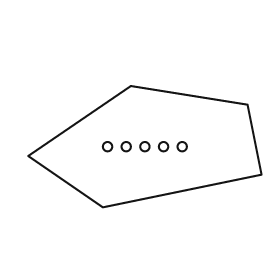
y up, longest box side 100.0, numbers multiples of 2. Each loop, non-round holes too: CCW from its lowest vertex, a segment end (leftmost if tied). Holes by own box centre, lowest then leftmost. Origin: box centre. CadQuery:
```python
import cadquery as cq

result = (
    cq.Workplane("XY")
    .moveTo(-18.0, -26.0)
    .lineTo(50.0, -12.0)
    .lineTo(44.0, 18.0)
    .lineTo(-6.0, 26.0)
    .lineTo(-50.0, -4.0)
    .close()
    .moveTo(-16.0, 0.0)
    .circle(2.0)
    .moveTo(-8.0, 0.0)
    .circle(2.0)
    .moveTo(0.0, 0.0)
    .circle(2.0)
    .moveTo(8.0, 0.0)
    .circle(2.0)
    .moveTo(16.0, 0.0)
    .circle(2.0)
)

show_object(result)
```